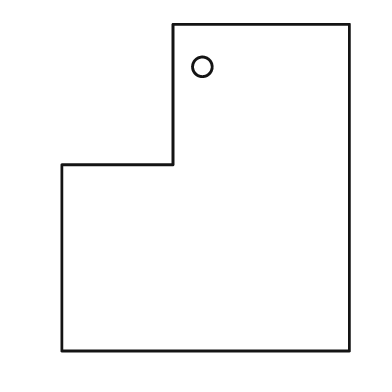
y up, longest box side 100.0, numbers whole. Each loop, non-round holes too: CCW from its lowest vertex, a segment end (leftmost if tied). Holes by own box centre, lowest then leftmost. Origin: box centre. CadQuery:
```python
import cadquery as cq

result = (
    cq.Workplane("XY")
    .moveTo(-44.0, -50.0)
    .lineTo(44.0, -50.0)
    .lineTo(44.0, 50.0)
    .lineTo(-10.0, 50.0)
    .lineTo(-10.0, 7.0)
    .lineTo(-44.0, 7.0)
    .close()
    .moveTo(-1.0, 37.0)
    .circle(3.0)
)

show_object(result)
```